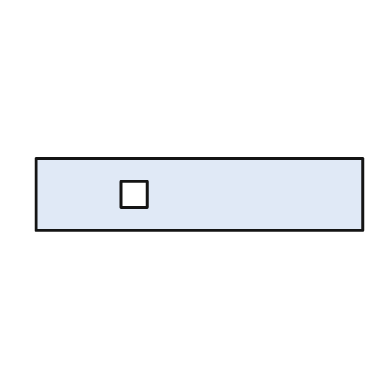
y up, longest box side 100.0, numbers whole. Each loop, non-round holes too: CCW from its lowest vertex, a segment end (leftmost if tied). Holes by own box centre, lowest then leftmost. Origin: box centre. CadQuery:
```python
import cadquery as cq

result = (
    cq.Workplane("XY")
    .moveTo(-50.0, -11.0)
    .lineTo(50.0, -11.0)
    .lineTo(50.0, 11.0)
    .lineTo(-50.0, 11.0)
    .close()
    .moveTo(-24.0, -4.0)
    .lineTo(-16.0, -4.0)
    .lineTo(-16.0, 4.0)
    .lineTo(-24.0, 4.0)
    .close()
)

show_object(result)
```